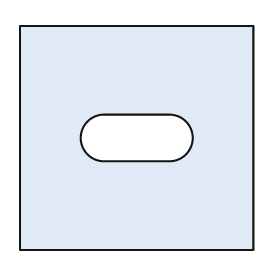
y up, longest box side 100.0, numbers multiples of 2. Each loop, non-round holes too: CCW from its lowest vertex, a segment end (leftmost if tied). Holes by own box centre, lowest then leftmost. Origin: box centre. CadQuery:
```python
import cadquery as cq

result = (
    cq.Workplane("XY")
    .moveTo(-50.0, -48.0)
    .lineTo(50.0, -48.0)
    .lineTo(50.0, 48.0)
    .lineTo(-50.0, 48.0)
    .close()
    .moveTo(-14.0, -10.0)
    .lineTo(14.0, -10.0)
    .threePointArc((24.0, 0.0), (14.0, 10.0))
    .lineTo(-14.0, 10.0)
    .threePointArc((-24.0, 0.0), (-14.0, -10.0))
    .close()
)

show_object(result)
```